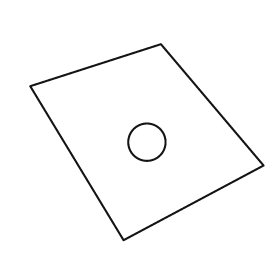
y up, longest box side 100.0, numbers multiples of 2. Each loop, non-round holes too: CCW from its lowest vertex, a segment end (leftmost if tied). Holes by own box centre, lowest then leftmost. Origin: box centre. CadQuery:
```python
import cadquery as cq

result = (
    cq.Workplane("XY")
    .moveTo(-10.0, -42.0)
    .lineTo(50.0, -10.0)
    .lineTo(6.0, 42.0)
    .lineTo(-50.0, 24.0)
    .close()
    .moveTo(0.0, 0.0)
    .circle(8.0)
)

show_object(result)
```